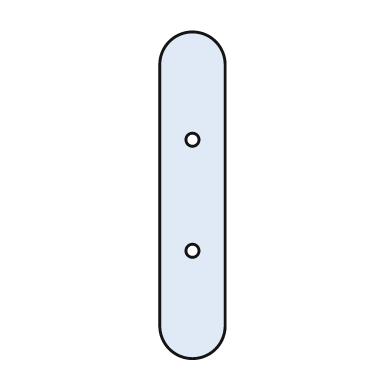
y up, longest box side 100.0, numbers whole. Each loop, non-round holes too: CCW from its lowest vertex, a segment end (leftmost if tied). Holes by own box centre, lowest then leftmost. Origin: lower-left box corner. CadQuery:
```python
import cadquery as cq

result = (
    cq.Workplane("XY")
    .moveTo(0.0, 10.0)
    .threePointArc((10.0, 0.0), (20.0, 10.0))
    .lineTo(20.0, 90.0)
    .threePointArc((10.0, 100.0), (0.0, 90.0))
    .close()
    .moveTo(10.0, 33.0)
    .circle(2.0)
    .moveTo(10.0, 67.0)
    .circle(2.0)
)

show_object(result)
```